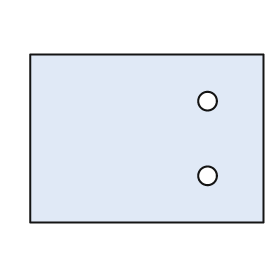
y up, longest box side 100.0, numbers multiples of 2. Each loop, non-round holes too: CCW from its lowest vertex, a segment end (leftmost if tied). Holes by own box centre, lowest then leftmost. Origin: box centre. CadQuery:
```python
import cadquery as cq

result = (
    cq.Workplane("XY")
    .moveTo(-50.0, -36.0)
    .lineTo(50.0, -36.0)
    .lineTo(50.0, 36.0)
    .lineTo(-50.0, 36.0)
    .close()
    .moveTo(26.0, -16.0)
    .circle(4.0)
    .moveTo(26.0, 16.0)
    .circle(4.0)
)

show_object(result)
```